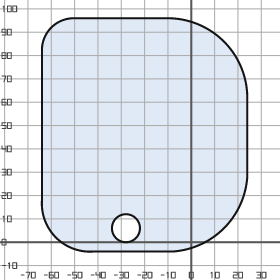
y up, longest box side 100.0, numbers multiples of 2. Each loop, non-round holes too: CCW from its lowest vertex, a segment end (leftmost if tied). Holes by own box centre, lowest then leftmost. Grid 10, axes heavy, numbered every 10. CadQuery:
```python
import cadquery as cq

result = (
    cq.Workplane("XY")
    .moveTo(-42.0, -4.0)
    .lineTo(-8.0, -4.0)
    .threePointArc((14.0, 6.0), (24.0, 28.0))
    .lineTo(24.0, 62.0)
    .threePointArc((14.0, 86.0), (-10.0, 96.0))
    .lineTo(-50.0, 96.0)
    .threePointArc((-60.0, 92.0), (-64.0, 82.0))
    .lineTo(-64.0, 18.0)
    .threePointArc((-58.0, 2.0), (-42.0, -4.0))
    .close()
    .moveTo(-28.0, 6.0)
    .circle(6.0)
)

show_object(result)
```